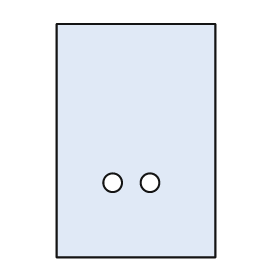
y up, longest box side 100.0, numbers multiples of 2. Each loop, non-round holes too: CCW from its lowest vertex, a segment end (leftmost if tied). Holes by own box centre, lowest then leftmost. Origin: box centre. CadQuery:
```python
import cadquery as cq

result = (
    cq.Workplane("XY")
    .moveTo(-34.0, -50.0)
    .lineTo(34.0, -50.0)
    .lineTo(34.0, 50.0)
    .lineTo(-34.0, 50.0)
    .close()
    .moveTo(-10.0, -18.0)
    .circle(4.0)
    .moveTo(6.0, -18.0)
    .circle(4.0)
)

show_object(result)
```